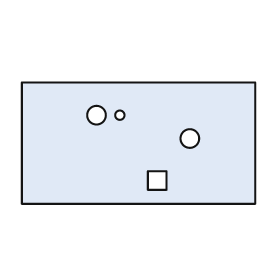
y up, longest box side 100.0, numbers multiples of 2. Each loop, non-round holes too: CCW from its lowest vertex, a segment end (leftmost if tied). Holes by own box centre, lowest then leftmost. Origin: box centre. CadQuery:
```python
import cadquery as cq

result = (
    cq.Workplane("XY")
    .moveTo(-50.0, -26.0)
    .lineTo(50.0, -26.0)
    .lineTo(50.0, 26.0)
    .lineTo(-50.0, 26.0)
    .close()
    .moveTo(4.0, -20.0)
    .lineTo(12.0, -20.0)
    .lineTo(12.0, -12.0)
    .lineTo(4.0, -12.0)
    .close()
    .moveTo(22.0, 2.0)
    .circle(4.0)
    .moveTo(-18.0, 12.0)
    .circle(4.0)
    .moveTo(-8.0, 12.0)
    .circle(2.0)
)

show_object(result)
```